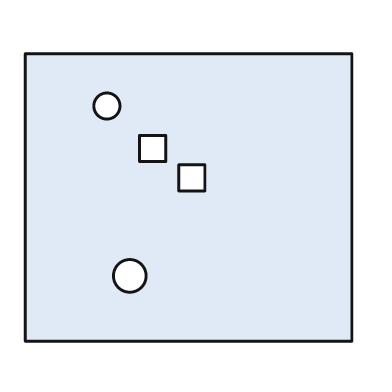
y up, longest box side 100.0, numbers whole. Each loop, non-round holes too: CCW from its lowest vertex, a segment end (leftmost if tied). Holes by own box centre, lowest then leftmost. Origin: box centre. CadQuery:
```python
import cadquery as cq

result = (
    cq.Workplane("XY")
    .moveTo(-50.0, -44.0)
    .lineTo(50.0, -44.0)
    .lineTo(50.0, 44.0)
    .lineTo(-50.0, 44.0)
    .close()
    .moveTo(-18.0, -24.0)
    .circle(5.0)
    .moveTo(-3.0, 2.0)
    .lineTo(5.0, 2.0)
    .lineTo(5.0, 10.0)
    .lineTo(-3.0, 10.0)
    .close()
    .moveTo(-15.0, 11.0)
    .lineTo(-7.0, 11.0)
    .lineTo(-7.0, 19.0)
    .lineTo(-15.0, 19.0)
    .close()
    .moveTo(-25.0, 28.0)
    .circle(4.0)
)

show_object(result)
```